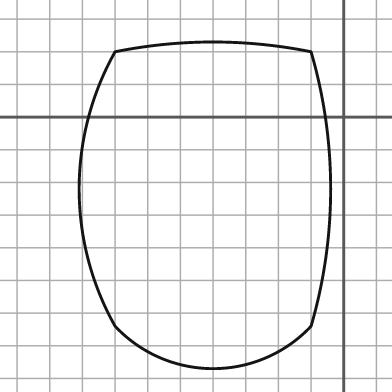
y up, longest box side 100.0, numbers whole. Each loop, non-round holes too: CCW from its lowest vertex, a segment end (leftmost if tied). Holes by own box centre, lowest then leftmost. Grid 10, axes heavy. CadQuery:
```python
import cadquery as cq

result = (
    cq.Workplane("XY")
    .moveTo(-70.0, -64.0)
    .threePointArc((-40.0, -77.0), (-10.0, -64.0))
    .threePointArc((-4.0, -22.0), (-10.0, 20.0))
    .threePointArc((-40.0, 23.0), (-70.0, 20.0))
    .threePointArc((-81.0, -22.0), (-70.0, -64.0))
    .close()
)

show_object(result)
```